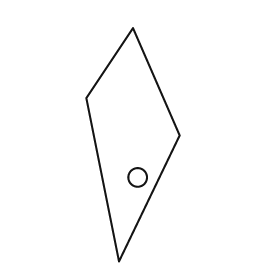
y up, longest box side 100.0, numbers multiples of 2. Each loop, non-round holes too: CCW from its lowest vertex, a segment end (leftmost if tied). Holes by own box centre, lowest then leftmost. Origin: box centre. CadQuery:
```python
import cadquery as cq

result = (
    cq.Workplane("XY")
    .moveTo(-6.0, -50.0)
    .lineTo(20.0, 4.0)
    .lineTo(0.0, 50.0)
    .lineTo(-20.0, 20.0)
    .close()
    .moveTo(2.0, -14.0)
    .circle(4.0)
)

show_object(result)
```